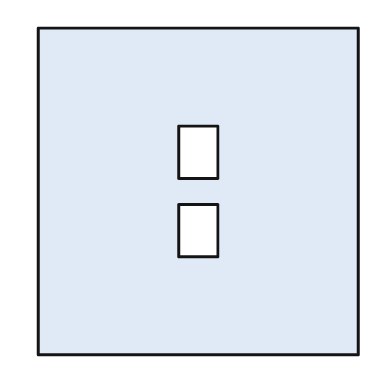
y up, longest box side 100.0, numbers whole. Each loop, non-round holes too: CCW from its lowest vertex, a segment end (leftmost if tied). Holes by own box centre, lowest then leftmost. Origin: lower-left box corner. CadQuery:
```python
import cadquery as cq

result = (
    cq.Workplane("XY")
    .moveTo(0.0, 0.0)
    .lineTo(98.0, 0.0)
    .lineTo(98.0, 100.0)
    .lineTo(0.0, 100.0)
    .close()
    .moveTo(43.0, 30.0)
    .lineTo(55.0, 30.0)
    .lineTo(55.0, 46.0)
    .lineTo(43.0, 46.0)
    .close()
    .moveTo(43.0, 54.0)
    .lineTo(55.0, 54.0)
    .lineTo(55.0, 70.0)
    .lineTo(43.0, 70.0)
    .close()
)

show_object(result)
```